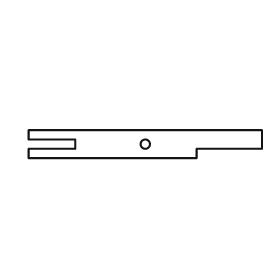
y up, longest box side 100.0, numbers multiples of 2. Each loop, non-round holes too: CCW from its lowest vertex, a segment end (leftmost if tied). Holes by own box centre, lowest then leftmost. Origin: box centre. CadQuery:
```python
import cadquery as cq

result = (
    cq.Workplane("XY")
    .moveTo(-50.0, -6.0)
    .lineTo(22.0, -6.0)
    .lineTo(22.0, -2.0)
    .lineTo(50.0, -2.0)
    .lineTo(50.0, 6.0)
    .lineTo(-50.0, 6.0)
    .lineTo(-50.0, 2.0)
    .lineTo(-30.0, 2.0)
    .lineTo(-30.0, -2.0)
    .lineTo(-50.0, -2.0)
    .close()
    .moveTo(0.0, 0.0)
    .circle(2.0)
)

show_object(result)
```